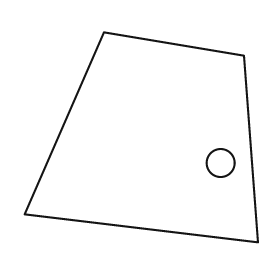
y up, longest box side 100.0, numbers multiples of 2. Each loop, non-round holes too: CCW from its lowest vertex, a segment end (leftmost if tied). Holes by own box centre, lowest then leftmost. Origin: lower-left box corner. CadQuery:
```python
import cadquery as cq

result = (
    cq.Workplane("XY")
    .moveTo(100.0, 0.0)
    .lineTo(94.0, 80.0)
    .lineTo(34.0, 90.0)
    .lineTo(0.0, 12.0)
    .close()
    .moveTo(84.0, 34.0)
    .circle(6.0)
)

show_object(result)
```